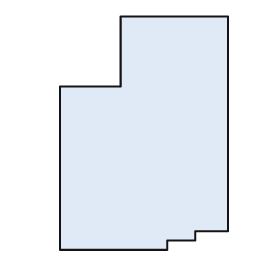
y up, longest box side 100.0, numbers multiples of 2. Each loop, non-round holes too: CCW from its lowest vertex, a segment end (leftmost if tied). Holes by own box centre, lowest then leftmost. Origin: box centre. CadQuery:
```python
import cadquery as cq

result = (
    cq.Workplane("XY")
    .moveTo(-36.0, -50.0)
    .lineTo(10.0, -50.0)
    .lineTo(10.0, -46.0)
    .lineTo(22.0, -46.0)
    .lineTo(22.0, -42.0)
    .lineTo(36.0, -42.0)
    .lineTo(36.0, 50.0)
    .lineTo(-10.0, 50.0)
    .lineTo(-10.0, 20.0)
    .lineTo(-36.0, 20.0)
    .close()
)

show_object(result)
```